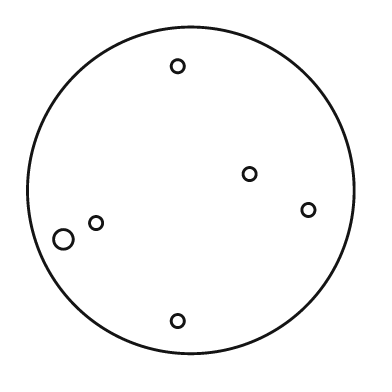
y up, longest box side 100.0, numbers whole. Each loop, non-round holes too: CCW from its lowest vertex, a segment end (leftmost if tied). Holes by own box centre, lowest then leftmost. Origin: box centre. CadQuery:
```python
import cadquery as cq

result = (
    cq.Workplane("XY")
    .moveTo(0.0, 0.0)
    .circle(50.0)
    .moveTo(-4.0, -40.0)
    .circle(2.0)
    .moveTo(-39.0, -15.0)
    .circle(3.0)
    .moveTo(-29.0, -10.0)
    .circle(2.0)
    .moveTo(36.0, -6.0)
    .circle(2.0)
    .moveTo(18.0, 5.0)
    .circle(2.0)
    .moveTo(-4.0, 38.0)
    .circle(2.0)
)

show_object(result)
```